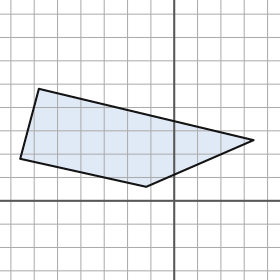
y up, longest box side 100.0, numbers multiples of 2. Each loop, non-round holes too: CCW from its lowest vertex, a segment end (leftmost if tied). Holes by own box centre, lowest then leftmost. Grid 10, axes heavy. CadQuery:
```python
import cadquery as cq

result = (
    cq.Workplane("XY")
    .moveTo(-12.0, 6.0)
    .lineTo(34.0, 26.0)
    .lineTo(-58.0, 48.0)
    .lineTo(-66.0, 18.0)
    .close()
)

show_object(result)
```